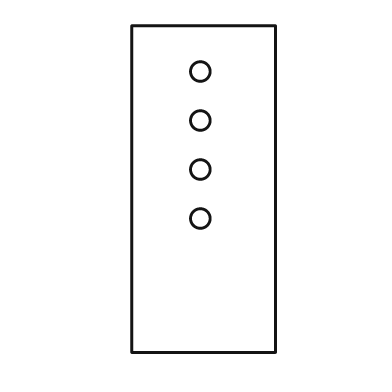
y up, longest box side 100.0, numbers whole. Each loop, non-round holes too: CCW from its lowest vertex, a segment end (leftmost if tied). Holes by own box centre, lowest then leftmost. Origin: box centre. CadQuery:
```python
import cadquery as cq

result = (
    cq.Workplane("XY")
    .moveTo(-22.0, -50.0)
    .lineTo(22.0, -50.0)
    .lineTo(22.0, 50.0)
    .lineTo(-22.0, 50.0)
    .close()
    .moveTo(-1.0, -9.0)
    .circle(3.0)
    .moveTo(-1.0, 6.0)
    .circle(3.0)
    .moveTo(-1.0, 21.0)
    .circle(3.0)
    .moveTo(-1.0, 36.0)
    .circle(3.0)
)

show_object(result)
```